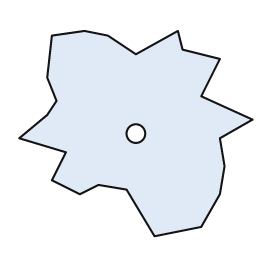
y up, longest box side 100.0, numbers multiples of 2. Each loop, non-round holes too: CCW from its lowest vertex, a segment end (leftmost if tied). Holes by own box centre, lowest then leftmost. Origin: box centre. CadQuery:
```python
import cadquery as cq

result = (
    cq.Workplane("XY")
    .moveTo(8.0, -44.0)
    .lineTo(28.0, -40.0)
    .lineTo(36.0, -26.0)
    .lineTo(38.0, -14.0)
    .lineTo(36.0, -2.0)
    .lineTo(50.0, 6.0)
    .lineTo(28.0, 16.0)
    .lineTo(36.0, 32.0)
    .lineTo(20.0, 36.0)
    .lineTo(18.0, 44.0)
    .lineTo(0.0, 34.0)
    .lineTo(-12.0, 42.0)
    .lineTo(-22.0, 44.0)
    .lineTo(-36.0, 42.0)
    .lineTo(-38.0, 24.0)
    .lineTo(-34.0, 14.0)
    .lineTo(-38.0, 8.0)
    .lineTo(-50.0, -2.0)
    .lineTo(-30.0, -8.0)
    .lineTo(-36.0, -20.0)
    .lineTo(-24.0, -26.0)
    .lineTo(-16.0, -22.0)
    .lineTo(-4.0, -24.0)
    .close()
    .moveTo(0.0, 0.0)
    .circle(4.0)
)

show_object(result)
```